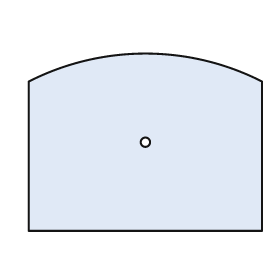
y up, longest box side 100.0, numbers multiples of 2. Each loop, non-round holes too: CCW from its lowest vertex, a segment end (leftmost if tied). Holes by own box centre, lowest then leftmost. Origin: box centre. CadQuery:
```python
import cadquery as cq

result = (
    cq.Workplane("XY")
    .moveTo(-50.0, -38.0)
    .lineTo(50.0, -38.0)
    .lineTo(50.0, 26.0)
    .threePointArc((0.0, 38.0), (-50.0, 26.0))
    .close()
    .moveTo(0.0, 0.0)
    .circle(2.0)
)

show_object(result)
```